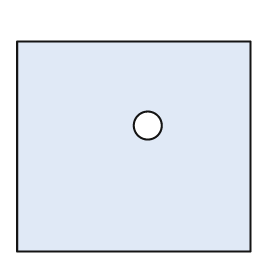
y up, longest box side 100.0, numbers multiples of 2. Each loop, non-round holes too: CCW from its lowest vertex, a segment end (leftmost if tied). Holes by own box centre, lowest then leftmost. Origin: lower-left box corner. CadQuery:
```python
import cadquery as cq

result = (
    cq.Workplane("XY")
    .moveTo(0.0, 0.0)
    .lineTo(100.0, 0.0)
    .lineTo(100.0, 90.0)
    .lineTo(0.0, 90.0)
    .close()
    .moveTo(56.0, 54.0)
    .circle(6.0)
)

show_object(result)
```